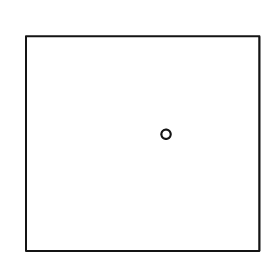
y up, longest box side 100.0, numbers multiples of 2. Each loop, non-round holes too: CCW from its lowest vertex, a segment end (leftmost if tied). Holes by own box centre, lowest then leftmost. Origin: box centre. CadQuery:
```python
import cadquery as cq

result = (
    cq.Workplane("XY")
    .moveTo(-50.0, -46.0)
    .lineTo(50.0, -46.0)
    .lineTo(50.0, 46.0)
    .lineTo(-50.0, 46.0)
    .close()
    .moveTo(10.0, 4.0)
    .circle(2.0)
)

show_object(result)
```